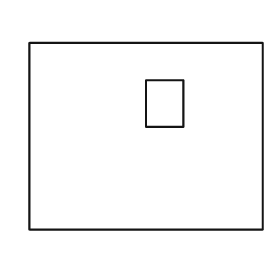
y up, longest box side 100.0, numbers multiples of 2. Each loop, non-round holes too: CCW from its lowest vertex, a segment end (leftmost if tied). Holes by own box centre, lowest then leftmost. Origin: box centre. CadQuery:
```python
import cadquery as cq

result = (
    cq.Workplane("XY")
    .moveTo(-50.0, -40.0)
    .lineTo(50.0, -40.0)
    .lineTo(50.0, 40.0)
    .lineTo(-50.0, 40.0)
    .close()
    .moveTo(0.0, 4.0)
    .lineTo(16.0, 4.0)
    .lineTo(16.0, 24.0)
    .lineTo(0.0, 24.0)
    .close()
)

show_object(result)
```